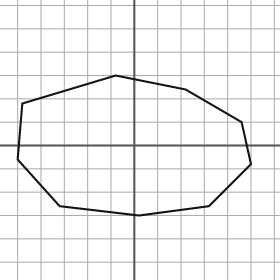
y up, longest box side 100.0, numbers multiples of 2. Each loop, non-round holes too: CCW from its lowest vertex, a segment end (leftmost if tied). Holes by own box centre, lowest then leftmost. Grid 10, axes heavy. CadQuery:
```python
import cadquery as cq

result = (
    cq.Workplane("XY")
    .moveTo(2.0, -30.0)
    .lineTo(32.0, -26.0)
    .lineTo(50.0, -8.0)
    .lineTo(46.0, 10.0)
    .lineTo(22.0, 24.0)
    .lineTo(-8.0, 30.0)
    .lineTo(-48.0, 18.0)
    .lineTo(-50.0, -6.0)
    .lineTo(-32.0, -26.0)
    .close()
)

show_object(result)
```